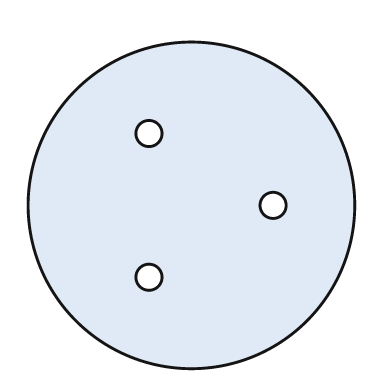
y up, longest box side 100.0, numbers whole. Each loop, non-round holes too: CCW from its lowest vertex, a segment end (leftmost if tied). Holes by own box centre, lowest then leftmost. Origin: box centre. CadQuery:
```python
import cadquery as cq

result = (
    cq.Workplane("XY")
    .moveTo(0.0, 0.0)
    .circle(50.0)
    .moveTo(-13.0, -22.0)
    .circle(4.0)
    .moveTo(25.0, 0.0)
    .circle(4.0)
    .moveTo(-13.0, 22.0)
    .circle(4.0)
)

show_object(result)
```